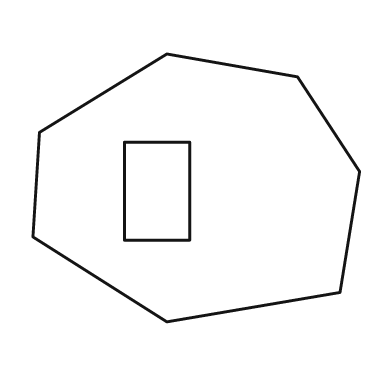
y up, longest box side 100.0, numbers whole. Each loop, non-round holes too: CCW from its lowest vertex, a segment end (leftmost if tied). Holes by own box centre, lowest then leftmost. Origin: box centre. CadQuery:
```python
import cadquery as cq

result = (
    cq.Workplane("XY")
    .moveTo(-9.0, -41.0)
    .lineTo(44.0, -32.0)
    .lineTo(50.0, 5.0)
    .lineTo(31.0, 34.0)
    .lineTo(-9.0, 41.0)
    .lineTo(-48.0, 17.0)
    .lineTo(-50.0, -15.0)
    .close()
    .moveTo(-22.0, -16.0)
    .lineTo(-2.0, -16.0)
    .lineTo(-2.0, 14.0)
    .lineTo(-22.0, 14.0)
    .close()
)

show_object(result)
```